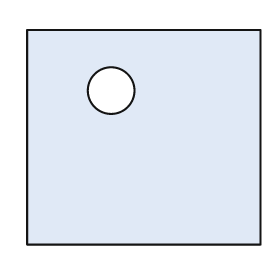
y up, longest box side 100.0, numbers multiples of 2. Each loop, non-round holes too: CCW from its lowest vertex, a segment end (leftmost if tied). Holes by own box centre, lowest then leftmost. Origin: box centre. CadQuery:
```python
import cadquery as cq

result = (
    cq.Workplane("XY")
    .moveTo(-50.0, -46.0)
    .lineTo(50.0, -46.0)
    .lineTo(50.0, 46.0)
    .lineTo(-50.0, 46.0)
    .close()
    .moveTo(-14.0, 20.0)
    .circle(10.0)
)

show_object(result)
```